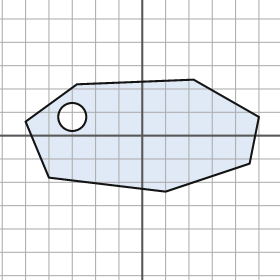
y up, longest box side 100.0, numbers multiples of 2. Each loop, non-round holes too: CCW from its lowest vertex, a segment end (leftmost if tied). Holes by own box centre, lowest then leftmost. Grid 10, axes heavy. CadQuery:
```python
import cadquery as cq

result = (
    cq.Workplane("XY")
    .moveTo(10.0, -24.0)
    .lineTo(46.0, -12.0)
    .lineTo(50.0, 8.0)
    .lineTo(22.0, 24.0)
    .lineTo(-28.0, 22.0)
    .lineTo(-50.0, 6.0)
    .lineTo(-40.0, -18.0)
    .close()
    .moveTo(-30.0, 8.0)
    .circle(6.0)
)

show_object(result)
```